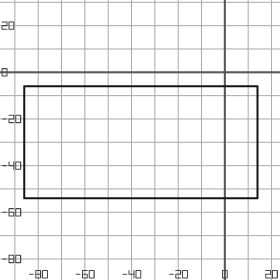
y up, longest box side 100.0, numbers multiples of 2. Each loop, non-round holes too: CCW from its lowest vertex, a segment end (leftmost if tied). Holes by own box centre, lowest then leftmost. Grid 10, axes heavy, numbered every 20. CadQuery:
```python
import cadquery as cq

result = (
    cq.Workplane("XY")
    .moveTo(-86.0, -54.0)
    .lineTo(14.0, -54.0)
    .lineTo(14.0, -6.0)
    .lineTo(-86.0, -6.0)
    .close()
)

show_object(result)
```